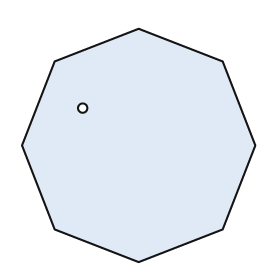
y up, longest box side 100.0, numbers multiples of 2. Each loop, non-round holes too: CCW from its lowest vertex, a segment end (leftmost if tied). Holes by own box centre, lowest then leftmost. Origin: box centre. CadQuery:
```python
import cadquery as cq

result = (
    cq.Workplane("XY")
    .moveTo(0.0, -50.0)
    .lineTo(36.0, -36.0)
    .lineTo(50.0, 0.0)
    .lineTo(36.0, 36.0)
    .lineTo(0.0, 50.0)
    .lineTo(-36.0, 36.0)
    .lineTo(-50.0, 0.0)
    .lineTo(-36.0, -36.0)
    .close()
    .moveTo(-24.0, 16.0)
    .circle(2.0)
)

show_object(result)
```